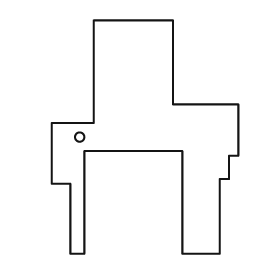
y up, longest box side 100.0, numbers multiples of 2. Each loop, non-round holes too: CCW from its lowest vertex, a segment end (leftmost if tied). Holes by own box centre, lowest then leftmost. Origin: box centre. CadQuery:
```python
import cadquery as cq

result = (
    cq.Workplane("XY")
    .moveTo(-32.0, -50.0)
    .lineTo(-26.0, -50.0)
    .lineTo(-26.0, -6.0)
    .lineTo(16.0, -6.0)
    .lineTo(16.0, -50.0)
    .lineTo(32.0, -50.0)
    .lineTo(32.0, -18.0)
    .lineTo(36.0, -18.0)
    .lineTo(36.0, -8.0)
    .lineTo(40.0, -8.0)
    .lineTo(40.0, 14.0)
    .lineTo(12.0, 14.0)
    .lineTo(12.0, 50.0)
    .lineTo(-22.0, 50.0)
    .lineTo(-22.0, 6.0)
    .lineTo(-40.0, 6.0)
    .lineTo(-40.0, -20.0)
    .lineTo(-32.0, -20.0)
    .close()
    .moveTo(-28.0, 0.0)
    .circle(2.0)
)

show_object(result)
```